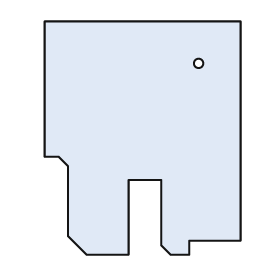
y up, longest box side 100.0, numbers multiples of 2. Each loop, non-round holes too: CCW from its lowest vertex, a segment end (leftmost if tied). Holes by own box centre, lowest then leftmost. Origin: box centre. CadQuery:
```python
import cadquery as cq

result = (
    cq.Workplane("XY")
    .moveTo(-24.0, -50.0)
    .lineTo(-6.0, -50.0)
    .lineTo(-6.0, -18.0)
    .lineTo(8.0, -18.0)
    .lineTo(8.0, -46.0)
    .lineTo(12.0, -50.0)
    .lineTo(20.0, -50.0)
    .lineTo(20.0, -44.0)
    .lineTo(42.0, -44.0)
    .lineTo(42.0, 50.0)
    .lineTo(-42.0, 50.0)
    .lineTo(-42.0, -8.0)
    .lineTo(-36.0, -8.0)
    .lineTo(-32.0, -12.0)
    .lineTo(-32.0, -42.0)
    .close()
    .moveTo(24.0, 32.0)
    .circle(2.0)
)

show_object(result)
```